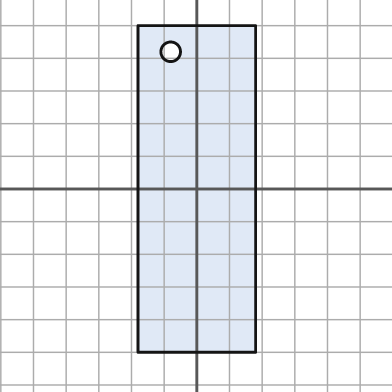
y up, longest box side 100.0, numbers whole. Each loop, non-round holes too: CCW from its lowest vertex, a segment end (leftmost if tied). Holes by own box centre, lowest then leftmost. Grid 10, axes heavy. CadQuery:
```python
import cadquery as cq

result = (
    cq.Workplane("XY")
    .moveTo(-18.0, -50.0)
    .lineTo(18.0, -50.0)
    .lineTo(18.0, 50.0)
    .lineTo(-18.0, 50.0)
    .close()
    .moveTo(-8.0, 42.0)
    .circle(3.0)
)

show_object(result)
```